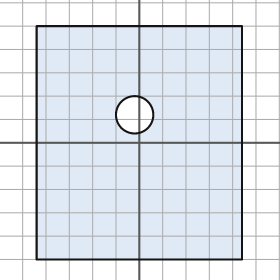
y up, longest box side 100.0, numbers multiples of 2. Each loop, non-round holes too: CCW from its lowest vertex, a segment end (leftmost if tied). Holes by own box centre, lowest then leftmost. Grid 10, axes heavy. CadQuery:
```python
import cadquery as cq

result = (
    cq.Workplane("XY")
    .moveTo(-44.0, -50.0)
    .lineTo(44.0, -50.0)
    .lineTo(44.0, 50.0)
    .lineTo(-44.0, 50.0)
    .close()
    .moveTo(-2.0, 12.0)
    .circle(8.0)
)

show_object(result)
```